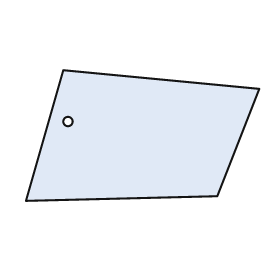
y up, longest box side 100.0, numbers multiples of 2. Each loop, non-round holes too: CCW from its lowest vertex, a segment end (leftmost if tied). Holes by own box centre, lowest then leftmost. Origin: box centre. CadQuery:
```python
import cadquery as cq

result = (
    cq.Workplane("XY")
    .moveTo(-50.0, -28.0)
    .lineTo(32.0, -26.0)
    .lineTo(50.0, 20.0)
    .lineTo(-34.0, 28.0)
    .close()
    .moveTo(-32.0, 6.0)
    .circle(2.0)
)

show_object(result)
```